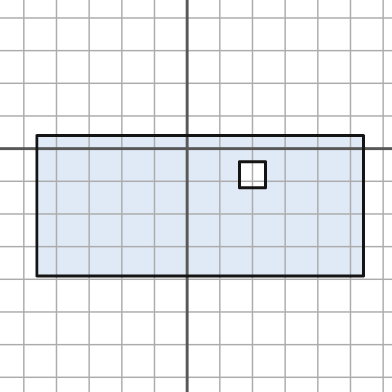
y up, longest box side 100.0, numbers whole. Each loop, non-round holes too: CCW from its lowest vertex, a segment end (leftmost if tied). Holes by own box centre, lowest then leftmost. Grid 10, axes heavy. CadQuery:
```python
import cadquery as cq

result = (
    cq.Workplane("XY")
    .moveTo(-46.0, -39.0)
    .lineTo(54.0, -39.0)
    .lineTo(54.0, 4.0)
    .lineTo(-46.0, 4.0)
    .close()
    .moveTo(16.0, -12.0)
    .lineTo(24.0, -12.0)
    .lineTo(24.0, -4.0)
    .lineTo(16.0, -4.0)
    .close()
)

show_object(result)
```